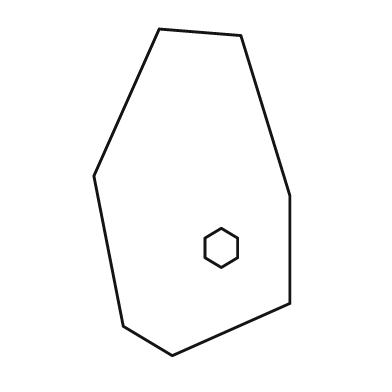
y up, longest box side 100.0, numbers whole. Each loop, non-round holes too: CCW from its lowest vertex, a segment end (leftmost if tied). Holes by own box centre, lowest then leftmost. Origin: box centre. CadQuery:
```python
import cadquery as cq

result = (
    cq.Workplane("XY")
    .moveTo(-6.0, -50.0)
    .lineTo(30.0, -34.0)
    .lineTo(30.0, -1.0)
    .lineTo(15.0, 48.0)
    .lineTo(-10.0, 50.0)
    .lineTo(-30.0, 5.0)
    .lineTo(-21.0, -41.0)
    .close()
    .moveTo(9.0, -23.0)
    .lineTo(14.0, -20.0)
    .lineTo(14.0, -14.0)
    .lineTo(9.0, -11.0)
    .lineTo(4.0, -14.0)
    .lineTo(4.0, -20.0)
    .close()
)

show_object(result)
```